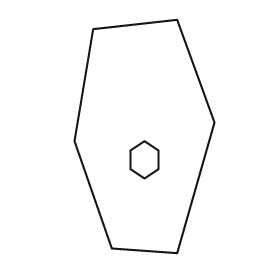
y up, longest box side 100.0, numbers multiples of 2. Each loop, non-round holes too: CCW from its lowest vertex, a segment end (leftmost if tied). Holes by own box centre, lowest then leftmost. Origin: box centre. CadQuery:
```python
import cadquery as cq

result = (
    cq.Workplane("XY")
    .moveTo(14.0, -50.0)
    .lineTo(30.0, 6.0)
    .lineTo(14.0, 50.0)
    .lineTo(-22.0, 46.0)
    .lineTo(-30.0, -2.0)
    .lineTo(-14.0, -48.0)
    .close()
    .moveTo(0.0, -18.0)
    .lineTo(6.0, -14.0)
    .lineTo(6.0, -6.0)
    .lineTo(0.0, -2.0)
    .lineTo(-6.0, -6.0)
    .lineTo(-6.0, -14.0)
    .close()
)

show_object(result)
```